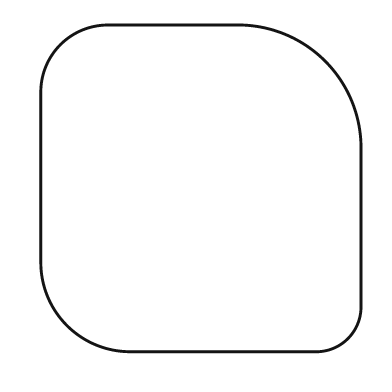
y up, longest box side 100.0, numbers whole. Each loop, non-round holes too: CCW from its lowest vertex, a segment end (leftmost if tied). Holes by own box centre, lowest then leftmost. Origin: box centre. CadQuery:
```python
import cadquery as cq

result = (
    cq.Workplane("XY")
    .moveTo(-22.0, -50.0)
    .lineTo(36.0, -50.0)
    .threePointArc((45.0, -46.0), (49.0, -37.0))
    .lineTo(49.0, 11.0)
    .threePointArc((38.0, 39.0), (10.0, 50.0))
    .lineTo(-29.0, 50.0)
    .threePointArc((-43.0, 44.0), (-49.0, 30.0))
    .lineTo(-49.0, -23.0)
    .threePointArc((-41.0, -42.0), (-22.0, -50.0))
    .close()
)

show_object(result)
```